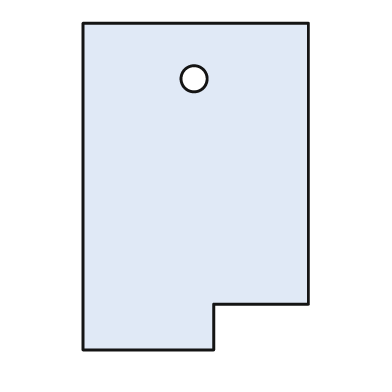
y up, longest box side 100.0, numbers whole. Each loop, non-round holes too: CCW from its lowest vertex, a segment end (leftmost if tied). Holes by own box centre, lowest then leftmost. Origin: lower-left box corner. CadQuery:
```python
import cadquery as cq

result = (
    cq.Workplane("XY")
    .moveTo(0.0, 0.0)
    .lineTo(40.0, 0.0)
    .lineTo(40.0, 14.0)
    .lineTo(69.0, 14.0)
    .lineTo(69.0, 100.0)
    .lineTo(0.0, 100.0)
    .close()
    .moveTo(34.0, 83.0)
    .circle(4.0)
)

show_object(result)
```